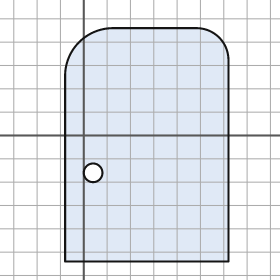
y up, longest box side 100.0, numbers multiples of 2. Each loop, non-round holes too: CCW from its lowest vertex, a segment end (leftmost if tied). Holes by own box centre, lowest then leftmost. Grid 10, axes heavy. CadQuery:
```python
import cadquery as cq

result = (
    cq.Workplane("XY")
    .moveTo(-8.0, -54.0)
    .lineTo(62.0, -54.0)
    .lineTo(62.0, 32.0)
    .threePointArc((58.0, 42.0), (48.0, 46.0))
    .lineTo(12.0, 46.0)
    .threePointArc((-2.0, 40.0), (-8.0, 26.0))
    .close()
    .moveTo(4.0, -16.0)
    .circle(4.0)
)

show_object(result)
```